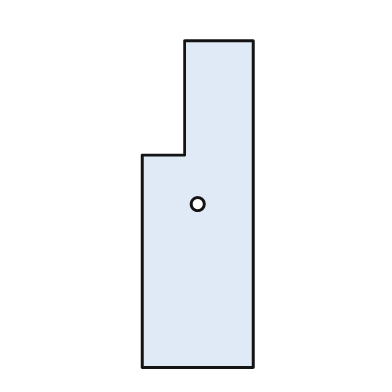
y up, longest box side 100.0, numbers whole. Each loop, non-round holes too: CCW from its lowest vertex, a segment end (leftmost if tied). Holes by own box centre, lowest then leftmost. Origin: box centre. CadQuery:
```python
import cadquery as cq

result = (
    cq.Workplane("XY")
    .moveTo(-17.0, -50.0)
    .lineTo(17.0, -50.0)
    .lineTo(17.0, 50.0)
    .lineTo(-4.0, 50.0)
    .lineTo(-4.0, 15.0)
    .lineTo(-17.0, 15.0)
    .close()
    .moveTo(0.0, 0.0)
    .circle(2.0)
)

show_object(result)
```